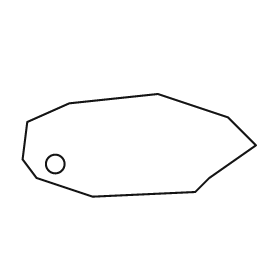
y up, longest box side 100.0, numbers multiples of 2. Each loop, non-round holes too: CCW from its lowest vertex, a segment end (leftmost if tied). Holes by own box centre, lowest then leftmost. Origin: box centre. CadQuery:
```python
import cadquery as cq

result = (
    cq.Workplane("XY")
    .moveTo(-20.0, -22.0)
    .lineTo(24.0, -20.0)
    .lineTo(30.0, -14.0)
    .lineTo(50.0, 0.0)
    .lineTo(38.0, 12.0)
    .lineTo(8.0, 22.0)
    .lineTo(-30.0, 18.0)
    .lineTo(-48.0, 10.0)
    .lineTo(-50.0, -6.0)
    .lineTo(-44.0, -14.0)
    .close()
    .moveTo(-36.0, -8.0)
    .circle(4.0)
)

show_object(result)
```